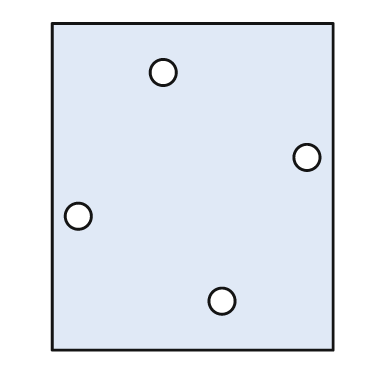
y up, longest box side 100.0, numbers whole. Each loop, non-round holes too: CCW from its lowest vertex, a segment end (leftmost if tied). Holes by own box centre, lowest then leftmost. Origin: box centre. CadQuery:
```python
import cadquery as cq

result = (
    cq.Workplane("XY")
    .moveTo(-43.0, -50.0)
    .lineTo(43.0, -50.0)
    .lineTo(43.0, 50.0)
    .lineTo(-43.0, 50.0)
    .close()
    .moveTo(9.0, -35.0)
    .circle(4.0)
    .moveTo(-35.0, -9.0)
    .circle(4.0)
    .moveTo(35.0, 9.0)
    .circle(4.0)
    .moveTo(-9.0, 35.0)
    .circle(4.0)
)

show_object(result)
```